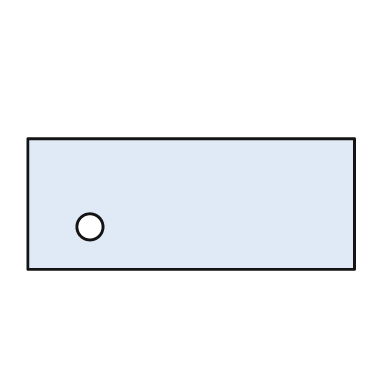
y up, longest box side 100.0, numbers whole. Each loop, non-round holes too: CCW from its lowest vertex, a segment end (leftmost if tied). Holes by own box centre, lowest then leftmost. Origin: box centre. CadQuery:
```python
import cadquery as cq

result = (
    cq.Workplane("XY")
    .moveTo(-50.0, -20.0)
    .lineTo(50.0, -20.0)
    .lineTo(50.0, 20.0)
    .lineTo(-50.0, 20.0)
    .close()
    .moveTo(-31.0, -7.0)
    .circle(4.0)
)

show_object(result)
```